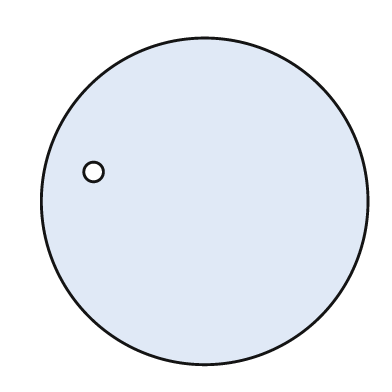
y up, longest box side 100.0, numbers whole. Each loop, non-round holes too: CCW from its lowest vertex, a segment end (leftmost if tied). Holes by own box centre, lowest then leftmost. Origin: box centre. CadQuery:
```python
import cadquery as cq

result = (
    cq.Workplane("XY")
    .moveTo(0.0, 0.0)
    .circle(50.0)
    .moveTo(-34.0, 9.0)
    .circle(3.0)
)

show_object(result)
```